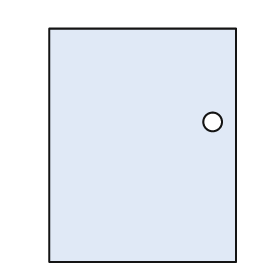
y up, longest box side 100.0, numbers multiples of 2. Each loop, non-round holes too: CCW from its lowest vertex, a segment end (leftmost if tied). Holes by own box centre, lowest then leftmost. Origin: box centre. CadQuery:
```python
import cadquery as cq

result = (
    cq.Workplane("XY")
    .moveTo(-40.0, -50.0)
    .lineTo(40.0, -50.0)
    .lineTo(40.0, 50.0)
    .lineTo(-40.0, 50.0)
    .close()
    .moveTo(30.0, 10.0)
    .circle(4.0)
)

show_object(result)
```